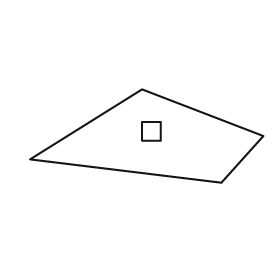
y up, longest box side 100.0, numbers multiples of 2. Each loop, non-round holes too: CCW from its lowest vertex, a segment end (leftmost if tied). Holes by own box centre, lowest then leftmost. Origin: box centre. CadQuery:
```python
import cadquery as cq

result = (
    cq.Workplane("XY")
    .moveTo(32.0, -20.0)
    .lineTo(50.0, 0.0)
    .lineTo(-2.0, 20.0)
    .lineTo(-50.0, -10.0)
    .close()
    .moveTo(-2.0, -2.0)
    .lineTo(6.0, -2.0)
    .lineTo(6.0, 6.0)
    .lineTo(-2.0, 6.0)
    .close()
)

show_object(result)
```